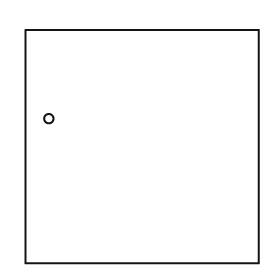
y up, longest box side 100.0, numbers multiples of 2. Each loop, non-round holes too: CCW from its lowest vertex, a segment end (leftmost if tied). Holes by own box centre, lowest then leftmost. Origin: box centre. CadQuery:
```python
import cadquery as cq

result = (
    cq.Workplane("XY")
    .moveTo(-50.0, -50.0)
    .lineTo(50.0, -50.0)
    .lineTo(50.0, 50.0)
    .lineTo(-50.0, 50.0)
    .close()
    .moveTo(-40.0, 12.0)
    .circle(2.0)
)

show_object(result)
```